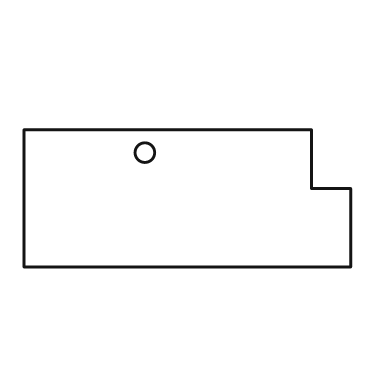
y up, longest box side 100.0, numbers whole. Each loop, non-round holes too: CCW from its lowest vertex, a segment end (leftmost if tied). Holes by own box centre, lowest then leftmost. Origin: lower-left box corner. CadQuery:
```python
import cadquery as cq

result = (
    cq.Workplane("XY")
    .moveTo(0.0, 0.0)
    .lineTo(100.0, 0.0)
    .lineTo(100.0, 24.0)
    .lineTo(88.0, 24.0)
    .lineTo(88.0, 42.0)
    .lineTo(0.0, 42.0)
    .close()
    .moveTo(37.0, 35.0)
    .circle(3.0)
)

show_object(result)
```